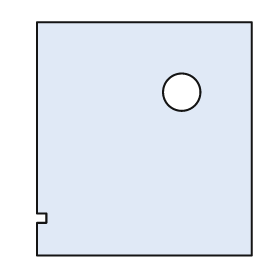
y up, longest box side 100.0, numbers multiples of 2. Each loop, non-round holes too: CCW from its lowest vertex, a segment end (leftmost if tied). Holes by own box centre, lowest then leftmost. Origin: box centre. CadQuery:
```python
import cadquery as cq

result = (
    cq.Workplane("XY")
    .moveTo(-46.0, -50.0)
    .lineTo(46.0, -50.0)
    .lineTo(46.0, 50.0)
    .lineTo(-46.0, 50.0)
    .lineTo(-46.0, -32.0)
    .lineTo(-42.0, -32.0)
    .lineTo(-42.0, -36.0)
    .lineTo(-46.0, -36.0)
    .close()
    .moveTo(16.0, 20.0)
    .circle(8.0)
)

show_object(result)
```